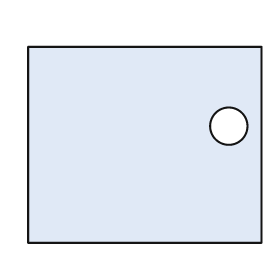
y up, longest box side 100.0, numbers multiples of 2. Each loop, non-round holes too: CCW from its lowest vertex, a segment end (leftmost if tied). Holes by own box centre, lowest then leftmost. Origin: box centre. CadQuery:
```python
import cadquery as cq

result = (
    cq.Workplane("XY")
    .moveTo(-50.0, -42.0)
    .lineTo(50.0, -42.0)
    .lineTo(50.0, 42.0)
    .lineTo(-50.0, 42.0)
    .close()
    .moveTo(36.0, 8.0)
    .circle(8.0)
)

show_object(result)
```